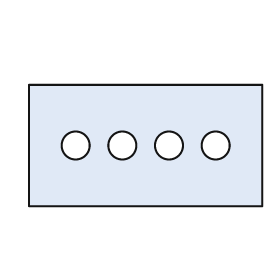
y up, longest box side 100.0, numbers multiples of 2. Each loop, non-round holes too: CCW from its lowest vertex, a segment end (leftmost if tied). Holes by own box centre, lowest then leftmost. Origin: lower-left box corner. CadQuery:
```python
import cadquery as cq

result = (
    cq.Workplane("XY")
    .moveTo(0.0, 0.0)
    .lineTo(100.0, 0.0)
    .lineTo(100.0, 52.0)
    .lineTo(0.0, 52.0)
    .close()
    .moveTo(20.0, 26.0)
    .circle(6.0)
    .moveTo(40.0, 26.0)
    .circle(6.0)
    .moveTo(60.0, 26.0)
    .circle(6.0)
    .moveTo(80.0, 26.0)
    .circle(6.0)
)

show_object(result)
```